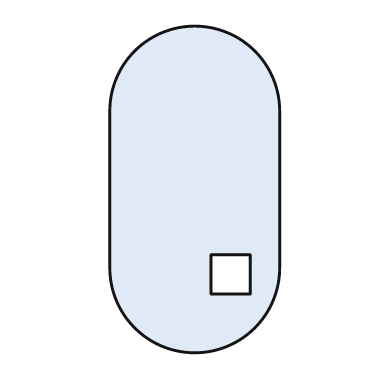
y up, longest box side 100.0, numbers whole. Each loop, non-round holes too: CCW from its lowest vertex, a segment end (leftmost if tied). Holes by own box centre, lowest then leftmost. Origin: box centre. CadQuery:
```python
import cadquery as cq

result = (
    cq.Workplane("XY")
    .moveTo(-26.0, -24.0)
    .threePointArc((0.0, -50.0), (26.0, -24.0))
    .lineTo(26.0, 24.0)
    .threePointArc((0.0, 50.0), (-26.0, 24.0))
    .close()
    .moveTo(5.0, -32.0)
    .lineTo(17.0, -32.0)
    .lineTo(17.0, -20.0)
    .lineTo(5.0, -20.0)
    .close()
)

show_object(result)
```